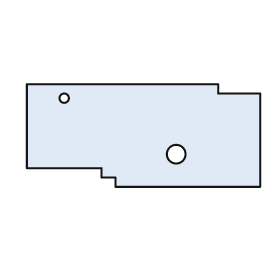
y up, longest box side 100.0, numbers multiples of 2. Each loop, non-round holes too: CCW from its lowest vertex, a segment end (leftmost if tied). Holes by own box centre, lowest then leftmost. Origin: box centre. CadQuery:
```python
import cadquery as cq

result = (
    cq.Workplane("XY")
    .moveTo(-12.0, -22.0)
    .lineTo(50.0, -22.0)
    .lineTo(50.0, 18.0)
    .lineTo(32.0, 18.0)
    .lineTo(32.0, 22.0)
    .lineTo(-50.0, 22.0)
    .lineTo(-50.0, -14.0)
    .lineTo(-18.0, -14.0)
    .lineTo(-18.0, -18.0)
    .lineTo(-12.0, -18.0)
    .close()
    .moveTo(14.0, -8.0)
    .circle(4.0)
    .moveTo(-34.0, 16.0)
    .circle(2.0)
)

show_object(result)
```